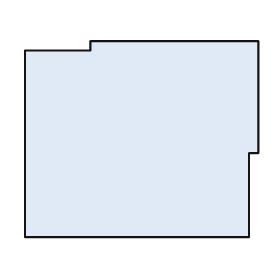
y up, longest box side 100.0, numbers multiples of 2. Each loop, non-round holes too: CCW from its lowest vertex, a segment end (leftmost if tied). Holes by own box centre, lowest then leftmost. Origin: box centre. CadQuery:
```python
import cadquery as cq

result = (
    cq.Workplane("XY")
    .moveTo(-50.0, -42.0)
    .lineTo(46.0, -42.0)
    .lineTo(46.0, -6.0)
    .lineTo(50.0, -6.0)
    .lineTo(50.0, 42.0)
    .lineTo(-22.0, 42.0)
    .lineTo(-22.0, 38.0)
    .lineTo(-50.0, 38.0)
    .close()
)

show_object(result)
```